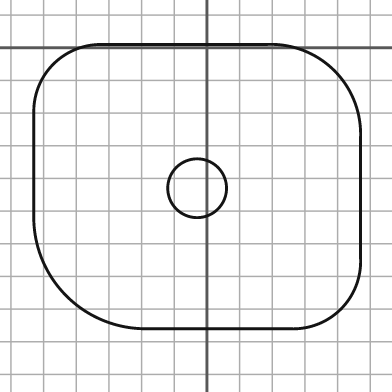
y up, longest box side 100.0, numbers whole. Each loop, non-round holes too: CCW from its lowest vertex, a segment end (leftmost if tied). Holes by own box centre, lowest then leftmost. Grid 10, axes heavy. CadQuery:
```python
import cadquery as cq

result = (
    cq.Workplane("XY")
    .moveTo(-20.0, -86.0)
    .lineTo(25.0, -86.0)
    .threePointArc((41.0, -80.0), (47.0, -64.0))
    .lineTo(47.0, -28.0)
    .threePointArc((39.0, -7.0), (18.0, 1.0))
    .lineTo(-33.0, 1.0)
    .threePointArc((-47.0, -5.0), (-53.0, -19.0))
    .lineTo(-53.0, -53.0)
    .threePointArc((-43.0, -76.0), (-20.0, -86.0))
    .close()
    .moveTo(-3.0, -43.0)
    .circle(9.0)
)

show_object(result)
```